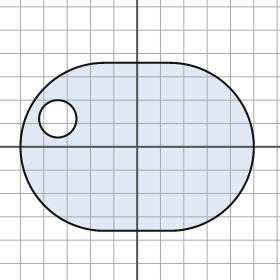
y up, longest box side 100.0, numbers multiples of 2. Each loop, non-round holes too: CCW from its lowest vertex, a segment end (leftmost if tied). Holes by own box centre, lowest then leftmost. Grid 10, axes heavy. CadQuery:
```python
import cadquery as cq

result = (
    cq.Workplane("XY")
    .moveTo(-14.0, -36.0)
    .lineTo(14.0, -36.0)
    .threePointArc((50.0, 0.0), (14.0, 36.0))
    .lineTo(-14.0, 36.0)
    .threePointArc((-50.0, 0.0), (-14.0, -36.0))
    .close()
    .moveTo(-34.0, 12.0)
    .circle(8.0)
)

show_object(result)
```